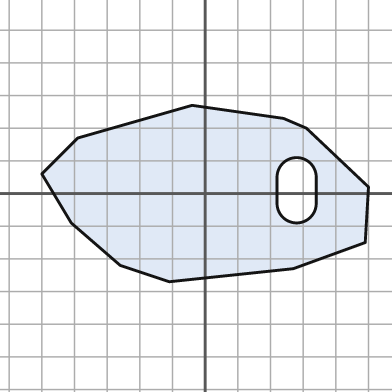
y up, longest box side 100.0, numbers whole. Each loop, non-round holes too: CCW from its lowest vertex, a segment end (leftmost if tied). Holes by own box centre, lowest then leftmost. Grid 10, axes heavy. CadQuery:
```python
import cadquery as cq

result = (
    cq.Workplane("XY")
    .moveTo(-11.0, -27.0)
    .lineTo(27.0, -23.0)
    .lineTo(49.0, -15.0)
    .lineTo(50.0, 2.0)
    .lineTo(31.0, 20.0)
    .lineTo(24.0, 23.0)
    .lineTo(-4.0, 27.0)
    .lineTo(-39.0, 17.0)
    .lineTo(-50.0, 6.0)
    .lineTo(-41.0, -9.0)
    .lineTo(-26.0, -22.0)
    .close()
    .moveTo(22.0, -3.0)
    .threePointArc((28.0, -9.0), (34.0, -3.0))
    .lineTo(34.0, 5.0)
    .threePointArc((28.0, 11.0), (22.0, 5.0))
    .close()
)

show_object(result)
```